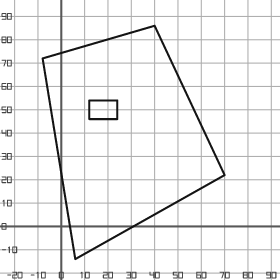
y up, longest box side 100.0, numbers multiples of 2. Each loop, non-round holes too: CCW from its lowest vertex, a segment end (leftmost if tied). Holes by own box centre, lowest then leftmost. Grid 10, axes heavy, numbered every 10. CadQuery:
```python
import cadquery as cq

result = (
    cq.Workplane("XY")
    .moveTo(6.0, -14.0)
    .lineTo(70.0, 22.0)
    .lineTo(40.0, 86.0)
    .lineTo(-8.0, 72.0)
    .close()
    .moveTo(12.0, 46.0)
    .lineTo(24.0, 46.0)
    .lineTo(24.0, 54.0)
    .lineTo(12.0, 54.0)
    .close()
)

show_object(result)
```